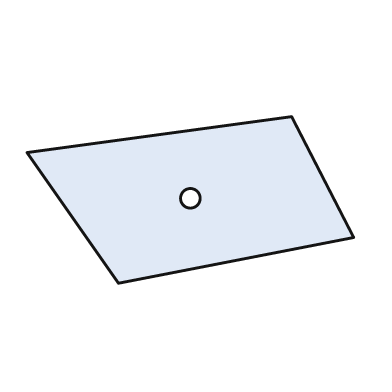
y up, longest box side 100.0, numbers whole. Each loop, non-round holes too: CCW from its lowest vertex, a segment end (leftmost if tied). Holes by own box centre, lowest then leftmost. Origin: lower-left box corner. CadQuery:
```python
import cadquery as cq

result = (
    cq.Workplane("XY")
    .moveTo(28.0, 0.0)
    .lineTo(100.0, 14.0)
    .lineTo(81.0, 51.0)
    .lineTo(0.0, 40.0)
    .close()
    .moveTo(50.0, 26.0)
    .circle(3.0)
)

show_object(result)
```